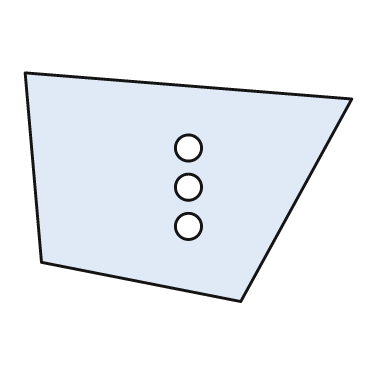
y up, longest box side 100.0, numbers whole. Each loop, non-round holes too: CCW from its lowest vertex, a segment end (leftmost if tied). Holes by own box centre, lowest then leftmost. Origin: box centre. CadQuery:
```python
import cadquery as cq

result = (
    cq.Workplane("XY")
    .moveTo(16.0, -35.0)
    .lineTo(50.0, 27.0)
    .lineTo(-50.0, 35.0)
    .lineTo(-45.0, -23.0)
    .close()
    .moveTo(0.0, -12.0)
    .circle(4.0)
    .moveTo(0.0, 0.0)
    .circle(4.0)
    .moveTo(0.0, 12.0)
    .circle(4.0)
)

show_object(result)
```